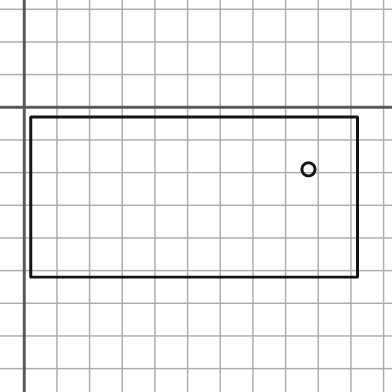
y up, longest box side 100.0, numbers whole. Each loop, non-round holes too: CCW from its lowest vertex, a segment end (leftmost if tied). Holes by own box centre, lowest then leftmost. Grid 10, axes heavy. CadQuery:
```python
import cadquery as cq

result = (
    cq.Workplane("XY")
    .moveTo(2.0, -52.0)
    .lineTo(102.0, -52.0)
    .lineTo(102.0, -3.0)
    .lineTo(2.0, -3.0)
    .close()
    .moveTo(87.0, -19.0)
    .circle(2.0)
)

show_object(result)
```